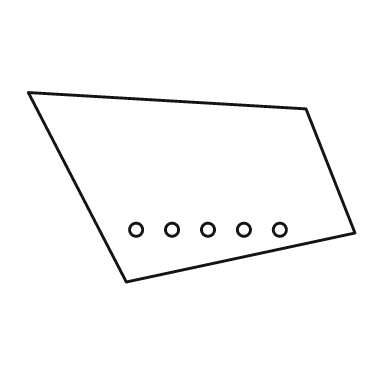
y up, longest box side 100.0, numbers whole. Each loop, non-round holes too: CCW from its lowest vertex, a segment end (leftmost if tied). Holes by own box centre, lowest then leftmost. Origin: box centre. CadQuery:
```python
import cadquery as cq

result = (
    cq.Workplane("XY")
    .moveTo(-20.0, -29.0)
    .lineTo(50.0, -14.0)
    .lineTo(35.0, 24.0)
    .lineTo(-50.0, 29.0)
    .close()
    .moveTo(-17.0, -13.0)
    .circle(2.0)
    .moveTo(-6.0, -13.0)
    .circle(2.0)
    .moveTo(5.0, -13.0)
    .circle(2.0)
    .moveTo(16.0, -13.0)
    .circle(2.0)
    .moveTo(27.0, -13.0)
    .circle(2.0)
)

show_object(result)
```